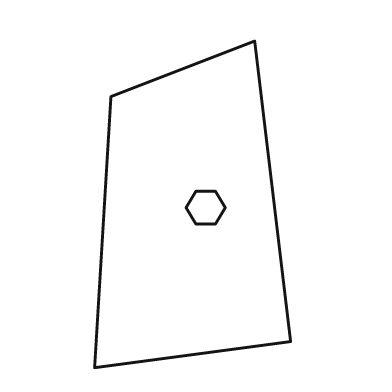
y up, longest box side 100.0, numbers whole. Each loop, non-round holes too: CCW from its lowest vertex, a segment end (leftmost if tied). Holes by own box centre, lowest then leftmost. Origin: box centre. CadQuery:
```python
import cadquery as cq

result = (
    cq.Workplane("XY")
    .moveTo(-30.0, -50.0)
    .lineTo(30.0, -42.0)
    .lineTo(19.0, 50.0)
    .lineTo(-25.0, 33.0)
    .close()
    .moveTo(1.0, -6.0)
    .lineTo(7.0, -6.0)
    .lineTo(10.0, -1.0)
    .lineTo(7.0, 4.0)
    .lineTo(1.0, 4.0)
    .lineTo(-2.0, -1.0)
    .close()
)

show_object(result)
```